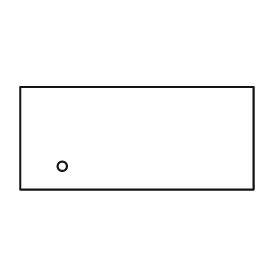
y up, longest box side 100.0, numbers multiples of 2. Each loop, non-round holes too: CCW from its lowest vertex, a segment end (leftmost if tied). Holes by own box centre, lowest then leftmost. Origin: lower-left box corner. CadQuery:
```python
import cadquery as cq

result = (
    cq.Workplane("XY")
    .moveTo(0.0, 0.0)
    .lineTo(100.0, 0.0)
    .lineTo(100.0, 44.0)
    .lineTo(0.0, 44.0)
    .close()
    .moveTo(18.0, 10.0)
    .circle(2.0)
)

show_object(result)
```